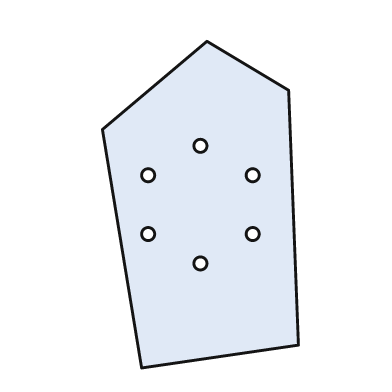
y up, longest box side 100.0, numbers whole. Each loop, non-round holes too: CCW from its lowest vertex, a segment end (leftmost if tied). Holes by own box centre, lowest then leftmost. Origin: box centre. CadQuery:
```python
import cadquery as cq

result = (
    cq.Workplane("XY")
    .moveTo(-18.0, -50.0)
    .lineTo(30.0, -43.0)
    .lineTo(27.0, 35.0)
    .lineTo(2.0, 50.0)
    .lineTo(-30.0, 23.0)
    .close()
    .moveTo(0.0, -18.0)
    .circle(2.0)
    .moveTo(-16.0, -9.0)
    .circle(2.0)
    .moveTo(16.0, -9.0)
    .circle(2.0)
    .moveTo(-16.0, 9.0)
    .circle(2.0)
    .moveTo(16.0, 9.0)
    .circle(2.0)
    .moveTo(0.0, 18.0)
    .circle(2.0)
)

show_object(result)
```